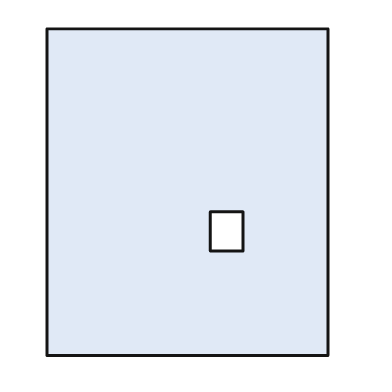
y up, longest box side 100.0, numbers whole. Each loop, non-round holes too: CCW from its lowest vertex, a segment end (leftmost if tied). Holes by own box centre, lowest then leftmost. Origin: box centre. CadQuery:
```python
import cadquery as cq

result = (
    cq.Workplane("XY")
    .moveTo(-43.0, -50.0)
    .lineTo(43.0, -50.0)
    .lineTo(43.0, 50.0)
    .lineTo(-43.0, 50.0)
    .close()
    .moveTo(7.0, -18.0)
    .lineTo(17.0, -18.0)
    .lineTo(17.0, -6.0)
    .lineTo(7.0, -6.0)
    .close()
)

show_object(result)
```